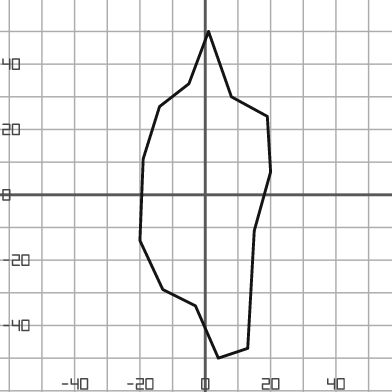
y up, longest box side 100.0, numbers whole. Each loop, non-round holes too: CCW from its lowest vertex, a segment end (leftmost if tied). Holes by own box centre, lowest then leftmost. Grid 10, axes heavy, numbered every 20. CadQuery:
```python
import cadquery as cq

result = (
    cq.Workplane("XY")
    .moveTo(4.0, -50.0)
    .lineTo(13.0, -47.0)
    .lineTo(15.0, -11.0)
    .lineTo(20.0, 7.0)
    .lineTo(19.0, 24.0)
    .lineTo(8.0, 30.0)
    .lineTo(1.0, 50.0)
    .lineTo(-5.0, 34.0)
    .lineTo(-14.0, 27.0)
    .lineTo(-19.0, 11.0)
    .lineTo(-20.0, -14.0)
    .lineTo(-13.0, -29.0)
    .lineTo(-3.0, -34.0)
    .close()
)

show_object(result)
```